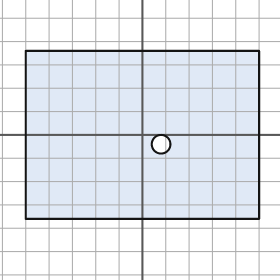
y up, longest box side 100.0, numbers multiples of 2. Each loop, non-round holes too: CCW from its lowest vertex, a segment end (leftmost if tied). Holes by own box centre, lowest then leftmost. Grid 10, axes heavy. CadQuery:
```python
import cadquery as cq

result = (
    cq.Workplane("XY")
    .moveTo(-50.0, -36.0)
    .lineTo(50.0, -36.0)
    .lineTo(50.0, 36.0)
    .lineTo(-50.0, 36.0)
    .close()
    .moveTo(8.0, -4.0)
    .circle(4.0)
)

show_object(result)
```